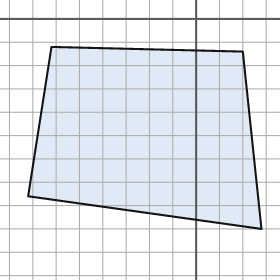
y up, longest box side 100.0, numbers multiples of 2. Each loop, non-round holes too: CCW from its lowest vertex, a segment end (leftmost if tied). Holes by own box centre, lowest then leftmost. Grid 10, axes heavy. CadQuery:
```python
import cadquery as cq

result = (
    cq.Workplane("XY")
    .moveTo(28.0, -90.0)
    .lineTo(20.0, -14.0)
    .lineTo(-62.0, -12.0)
    .lineTo(-72.0, -76.0)
    .close()
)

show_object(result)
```